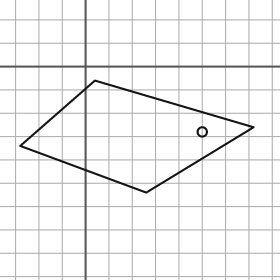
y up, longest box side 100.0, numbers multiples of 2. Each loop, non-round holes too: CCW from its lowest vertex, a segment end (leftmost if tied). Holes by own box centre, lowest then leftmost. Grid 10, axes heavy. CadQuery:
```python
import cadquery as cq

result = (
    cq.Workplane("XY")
    .moveTo(26.0, -54.0)
    .lineTo(72.0, -26.0)
    .lineTo(4.0, -6.0)
    .lineTo(-28.0, -34.0)
    .close()
    .moveTo(50.0, -28.0)
    .circle(2.0)
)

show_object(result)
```